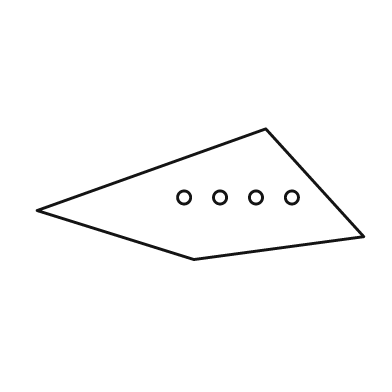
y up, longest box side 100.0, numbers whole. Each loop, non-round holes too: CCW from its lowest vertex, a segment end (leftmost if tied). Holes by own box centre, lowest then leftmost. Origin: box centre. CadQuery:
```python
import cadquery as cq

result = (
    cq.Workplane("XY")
    .moveTo(-2.0, -20.0)
    .lineTo(50.0, -13.0)
    .lineTo(20.0, 20.0)
    .lineTo(-50.0, -5.0)
    .close()
    .moveTo(-5.0, -1.0)
    .circle(2.0)
    .moveTo(6.0, -1.0)
    .circle(2.0)
    .moveTo(17.0, -1.0)
    .circle(2.0)
    .moveTo(28.0, -1.0)
    .circle(2.0)
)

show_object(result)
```